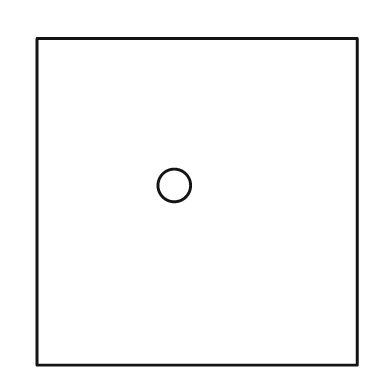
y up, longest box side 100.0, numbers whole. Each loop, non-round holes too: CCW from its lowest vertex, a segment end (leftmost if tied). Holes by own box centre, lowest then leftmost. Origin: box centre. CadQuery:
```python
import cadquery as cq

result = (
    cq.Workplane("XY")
    .moveTo(-49.0, -50.0)
    .lineTo(49.0, -50.0)
    .lineTo(49.0, 50.0)
    .lineTo(-49.0, 50.0)
    .close()
    .moveTo(-7.0, 5.0)
    .circle(5.0)
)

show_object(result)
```